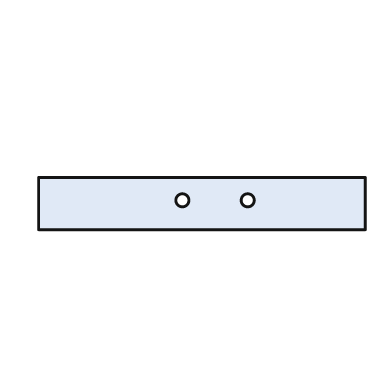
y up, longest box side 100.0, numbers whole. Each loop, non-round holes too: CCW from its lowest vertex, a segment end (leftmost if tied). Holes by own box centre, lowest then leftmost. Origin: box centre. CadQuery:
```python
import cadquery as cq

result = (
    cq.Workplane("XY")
    .moveTo(-50.0, -8.0)
    .lineTo(50.0, -8.0)
    .lineTo(50.0, 8.0)
    .lineTo(-50.0, 8.0)
    .close()
    .moveTo(-6.0, 1.0)
    .circle(2.0)
    .moveTo(14.0, 1.0)
    .circle(2.0)
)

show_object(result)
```